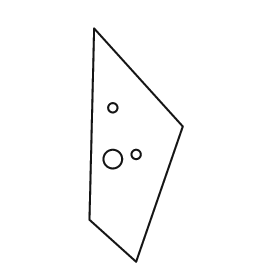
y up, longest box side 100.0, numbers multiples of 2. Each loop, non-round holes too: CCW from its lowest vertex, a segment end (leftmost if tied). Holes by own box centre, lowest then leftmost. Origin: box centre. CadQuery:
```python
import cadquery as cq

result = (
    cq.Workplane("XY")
    .moveTo(0.0, -50.0)
    .lineTo(20.0, 8.0)
    .lineTo(-18.0, 50.0)
    .lineTo(-20.0, -32.0)
    .close()
    .moveTo(-10.0, -6.0)
    .circle(4.0)
    .moveTo(0.0, -4.0)
    .circle(2.0)
    .moveTo(-10.0, 16.0)
    .circle(2.0)
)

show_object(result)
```